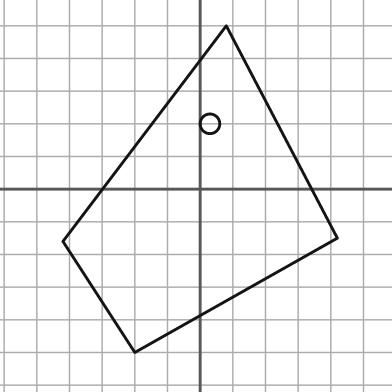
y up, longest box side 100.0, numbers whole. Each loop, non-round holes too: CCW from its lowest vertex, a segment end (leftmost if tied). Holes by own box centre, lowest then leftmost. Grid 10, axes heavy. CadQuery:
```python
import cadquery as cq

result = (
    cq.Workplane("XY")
    .moveTo(-20.0, -50.0)
    .lineTo(42.0, -15.0)
    .lineTo(8.0, 50.0)
    .lineTo(-42.0, -16.0)
    .close()
    .moveTo(3.0, 20.0)
    .circle(3.0)
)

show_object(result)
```